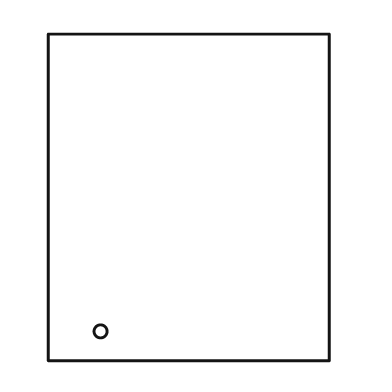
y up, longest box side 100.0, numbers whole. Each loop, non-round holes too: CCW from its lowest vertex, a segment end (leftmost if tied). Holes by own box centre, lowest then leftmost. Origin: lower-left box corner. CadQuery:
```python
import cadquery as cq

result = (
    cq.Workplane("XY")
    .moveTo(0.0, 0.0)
    .lineTo(86.0, 0.0)
    .lineTo(86.0, 100.0)
    .lineTo(0.0, 100.0)
    .close()
    .moveTo(16.0, 9.0)
    .circle(2.0)
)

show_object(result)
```